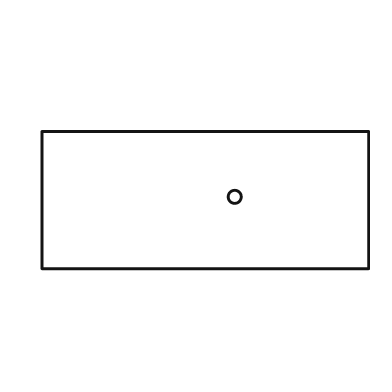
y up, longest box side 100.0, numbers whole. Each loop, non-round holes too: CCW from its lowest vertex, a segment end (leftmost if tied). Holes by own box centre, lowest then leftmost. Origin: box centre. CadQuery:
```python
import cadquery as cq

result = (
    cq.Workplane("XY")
    .moveTo(-50.0, -21.0)
    .lineTo(50.0, -21.0)
    .lineTo(50.0, 21.0)
    .lineTo(-50.0, 21.0)
    .close()
    .moveTo(9.0, 1.0)
    .circle(2.0)
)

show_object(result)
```